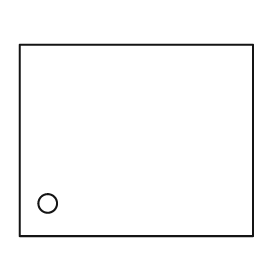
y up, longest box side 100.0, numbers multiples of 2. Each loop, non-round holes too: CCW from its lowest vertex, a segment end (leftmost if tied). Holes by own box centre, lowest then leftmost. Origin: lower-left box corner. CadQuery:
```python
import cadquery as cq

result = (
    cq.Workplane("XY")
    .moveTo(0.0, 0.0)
    .lineTo(100.0, 0.0)
    .lineTo(100.0, 82.0)
    .lineTo(0.0, 82.0)
    .close()
    .moveTo(12.0, 14.0)
    .circle(4.0)
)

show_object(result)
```